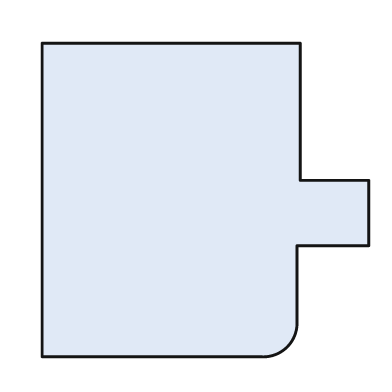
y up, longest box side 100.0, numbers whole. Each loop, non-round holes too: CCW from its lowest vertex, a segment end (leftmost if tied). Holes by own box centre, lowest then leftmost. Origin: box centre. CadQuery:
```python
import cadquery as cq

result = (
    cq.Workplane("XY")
    .moveTo(-50.0, -48.0)
    .lineTo(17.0, -48.0)
    .threePointArc((25.0, -45.0), (28.0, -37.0))
    .lineTo(28.0, -14.0)
    .lineTo(50.0, -14.0)
    .lineTo(50.0, 6.0)
    .lineTo(29.0, 6.0)
    .lineTo(29.0, 48.0)
    .lineTo(-50.0, 48.0)
    .close()
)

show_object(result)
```